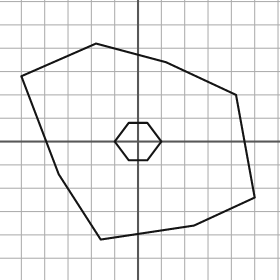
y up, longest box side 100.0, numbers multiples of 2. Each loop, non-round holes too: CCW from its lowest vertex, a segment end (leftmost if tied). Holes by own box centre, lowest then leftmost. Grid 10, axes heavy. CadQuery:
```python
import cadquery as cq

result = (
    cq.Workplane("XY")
    .moveTo(-16.0, -42.0)
    .lineTo(24.0, -36.0)
    .lineTo(50.0, -24.0)
    .lineTo(42.0, 20.0)
    .lineTo(12.0, 34.0)
    .lineTo(-18.0, 42.0)
    .lineTo(-50.0, 28.0)
    .lineTo(-34.0, -14.0)
    .close()
    .moveTo(-4.0, -8.0)
    .lineTo(4.0, -8.0)
    .lineTo(10.0, 0.0)
    .lineTo(4.0, 8.0)
    .lineTo(-4.0, 8.0)
    .lineTo(-10.0, 0.0)
    .close()
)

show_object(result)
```